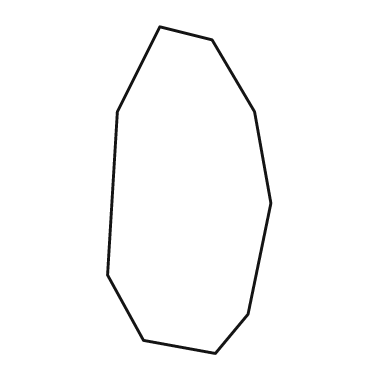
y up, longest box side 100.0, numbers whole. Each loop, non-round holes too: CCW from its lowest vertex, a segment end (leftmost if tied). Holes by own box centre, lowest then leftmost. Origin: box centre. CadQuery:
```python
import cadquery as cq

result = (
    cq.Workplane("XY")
    .moveTo(8.0, -50.0)
    .lineTo(18.0, -38.0)
    .lineTo(25.0, -4.0)
    .lineTo(20.0, 24.0)
    .lineTo(7.0, 46.0)
    .lineTo(-9.0, 50.0)
    .lineTo(-22.0, 24.0)
    .lineTo(-25.0, -26.0)
    .lineTo(-14.0, -46.0)
    .close()
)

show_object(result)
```